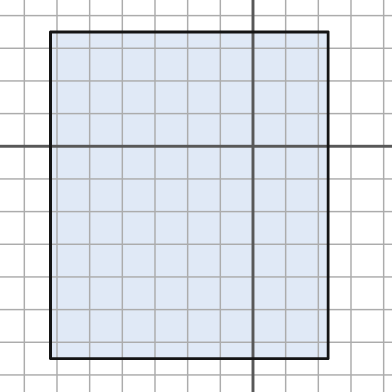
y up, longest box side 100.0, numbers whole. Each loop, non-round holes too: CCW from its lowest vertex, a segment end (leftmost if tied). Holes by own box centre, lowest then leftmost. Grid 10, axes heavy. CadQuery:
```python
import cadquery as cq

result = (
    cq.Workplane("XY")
    .moveTo(-62.0, -65.0)
    .lineTo(23.0, -65.0)
    .lineTo(23.0, 35.0)
    .lineTo(-62.0, 35.0)
    .close()
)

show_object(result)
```